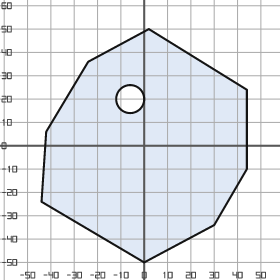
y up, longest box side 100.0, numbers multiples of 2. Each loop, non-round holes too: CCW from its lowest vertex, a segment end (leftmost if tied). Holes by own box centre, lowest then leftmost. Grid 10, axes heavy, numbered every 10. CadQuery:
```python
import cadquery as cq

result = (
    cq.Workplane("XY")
    .moveTo(0.0, -50.0)
    .lineTo(30.0, -34.0)
    .lineTo(44.0, -10.0)
    .lineTo(44.0, 24.0)
    .lineTo(2.0, 50.0)
    .lineTo(-24.0, 36.0)
    .lineTo(-42.0, 6.0)
    .lineTo(-44.0, -24.0)
    .close()
    .moveTo(-6.0, 20.0)
    .circle(6.0)
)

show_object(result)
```